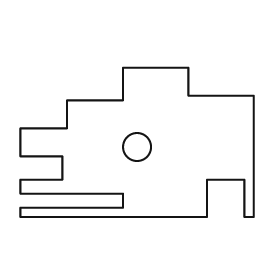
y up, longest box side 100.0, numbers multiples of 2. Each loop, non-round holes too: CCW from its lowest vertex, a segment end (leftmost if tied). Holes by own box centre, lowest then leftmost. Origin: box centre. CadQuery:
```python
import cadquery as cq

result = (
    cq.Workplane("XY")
    .moveTo(-50.0, -32.0)
    .lineTo(30.0, -32.0)
    .lineTo(30.0, -16.0)
    .lineTo(46.0, -16.0)
    .lineTo(46.0, -32.0)
    .lineTo(50.0, -32.0)
    .lineTo(50.0, 20.0)
    .lineTo(22.0, 20.0)
    .lineTo(22.0, 32.0)
    .lineTo(-6.0, 32.0)
    .lineTo(-6.0, 18.0)
    .lineTo(-30.0, 18.0)
    .lineTo(-30.0, 6.0)
    .lineTo(-50.0, 6.0)
    .lineTo(-50.0, -6.0)
    .lineTo(-32.0, -6.0)
    .lineTo(-32.0, -16.0)
    .lineTo(-50.0, -16.0)
    .lineTo(-50.0, -22.0)
    .lineTo(-6.0, -22.0)
    .lineTo(-6.0, -28.0)
    .lineTo(-50.0, -28.0)
    .close()
    .moveTo(0.0, -2.0)
    .circle(6.0)
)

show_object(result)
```